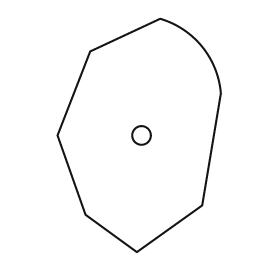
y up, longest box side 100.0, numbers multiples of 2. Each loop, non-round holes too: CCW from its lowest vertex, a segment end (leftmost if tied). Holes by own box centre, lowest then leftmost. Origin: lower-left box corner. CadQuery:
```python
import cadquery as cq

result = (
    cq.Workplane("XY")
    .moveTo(34.0, 0.0)
    .lineTo(62.0, 20.0)
    .lineTo(70.0, 68.0)
    .threePointArc((62.0, 88.0), (44.0, 100.0))
    .lineTo(14.0, 86.0)
    .lineTo(0.0, 50.0)
    .lineTo(12.0, 16.0)
    .close()
    .moveTo(36.0, 50.0)
    .circle(4.0)
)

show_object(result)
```